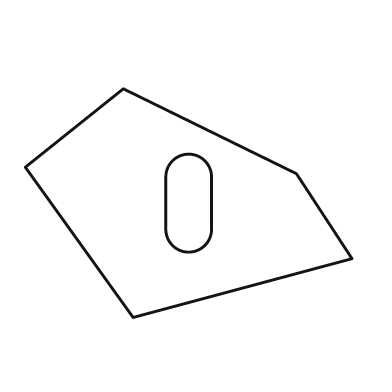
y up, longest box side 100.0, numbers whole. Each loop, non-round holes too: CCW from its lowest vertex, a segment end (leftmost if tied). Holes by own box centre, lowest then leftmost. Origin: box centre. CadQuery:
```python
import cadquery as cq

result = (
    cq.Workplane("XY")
    .moveTo(-17.0, -35.0)
    .lineTo(50.0, -17.0)
    .lineTo(33.0, 9.0)
    .lineTo(-20.0, 35.0)
    .lineTo(-50.0, 11.0)
    .close()
    .moveTo(-7.0, -8.0)
    .threePointArc((0.0, -15.0), (7.0, -8.0))
    .lineTo(7.0, 8.0)
    .threePointArc((0.0, 15.0), (-7.0, 8.0))
    .close()
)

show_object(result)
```